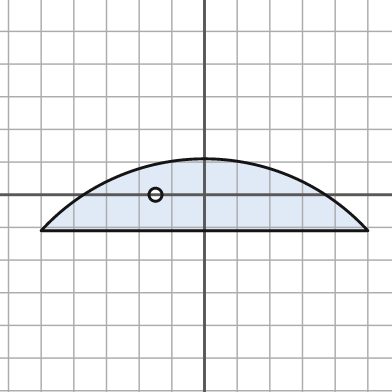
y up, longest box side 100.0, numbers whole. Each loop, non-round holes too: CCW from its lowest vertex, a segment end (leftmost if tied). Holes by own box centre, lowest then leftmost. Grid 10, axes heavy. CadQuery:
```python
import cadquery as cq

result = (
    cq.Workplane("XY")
    .moveTo(-50.0, -11.0)
    .lineTo(50.0, -11.0)
    .threePointArc((0.0, 11.0), (-50.0, -11.0))
    .close()
    .moveTo(-15.0, 0.0)
    .circle(2.0)
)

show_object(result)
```